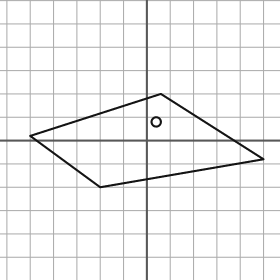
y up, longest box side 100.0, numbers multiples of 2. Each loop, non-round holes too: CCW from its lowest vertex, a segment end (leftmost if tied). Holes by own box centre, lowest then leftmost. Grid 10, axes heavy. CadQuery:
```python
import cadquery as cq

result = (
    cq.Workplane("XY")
    .moveTo(-20.0, -20.0)
    .lineTo(50.0, -8.0)
    .lineTo(6.0, 20.0)
    .lineTo(-50.0, 2.0)
    .close()
    .moveTo(4.0, 8.0)
    .circle(2.0)
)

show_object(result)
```